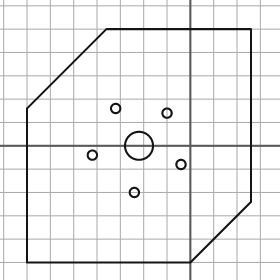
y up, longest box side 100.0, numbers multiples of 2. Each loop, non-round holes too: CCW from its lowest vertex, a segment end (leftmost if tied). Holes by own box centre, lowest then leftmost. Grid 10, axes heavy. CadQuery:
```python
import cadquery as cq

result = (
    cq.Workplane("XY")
    .moveTo(-70.0, -50.0)
    .lineTo(0.0, -50.0)
    .lineTo(26.0, -24.0)
    .lineTo(26.0, 50.0)
    .lineTo(-36.0, 50.0)
    .lineTo(-70.0, 16.0)
    .close()
    .moveTo(-24.0, -20.0)
    .circle(2.0)
    .moveTo(-4.0, -8.0)
    .circle(2.0)
    .moveTo(-42.0, -4.0)
    .circle(2.0)
    .moveTo(-22.0, 0.0)
    .circle(6.0)
    .moveTo(-10.0, 14.0)
    .circle(2.0)
    .moveTo(-32.0, 16.0)
    .circle(2.0)
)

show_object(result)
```